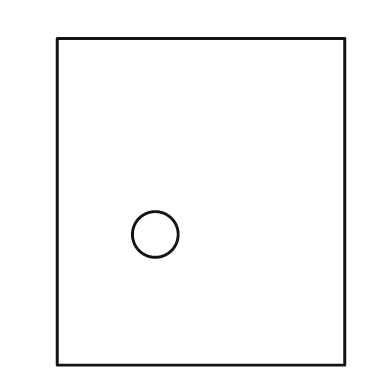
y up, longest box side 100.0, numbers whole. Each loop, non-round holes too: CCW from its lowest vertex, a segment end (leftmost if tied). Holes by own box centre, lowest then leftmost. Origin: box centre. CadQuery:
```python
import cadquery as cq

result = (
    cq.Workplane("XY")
    .moveTo(-44.0, -50.0)
    .lineTo(44.0, -50.0)
    .lineTo(44.0, 50.0)
    .lineTo(-44.0, 50.0)
    .close()
    .moveTo(-14.0, -10.0)
    .circle(7.0)
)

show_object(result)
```